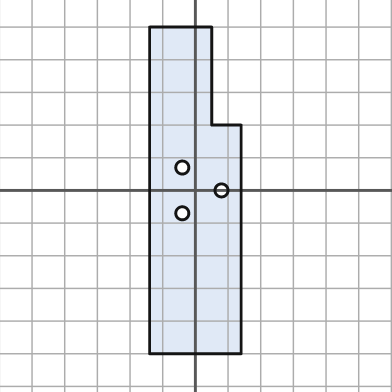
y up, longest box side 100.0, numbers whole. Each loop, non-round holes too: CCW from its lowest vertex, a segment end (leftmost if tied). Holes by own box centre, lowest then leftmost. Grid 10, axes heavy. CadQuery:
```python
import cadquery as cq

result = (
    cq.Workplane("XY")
    .moveTo(-14.0, -50.0)
    .lineTo(14.0, -50.0)
    .lineTo(14.0, 20.0)
    .lineTo(5.0, 20.0)
    .lineTo(5.0, 50.0)
    .lineTo(-14.0, 50.0)
    .close()
    .moveTo(-4.0, -7.0)
    .circle(2.0)
    .moveTo(8.0, 0.0)
    .circle(2.0)
    .moveTo(-4.0, 7.0)
    .circle(2.0)
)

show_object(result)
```